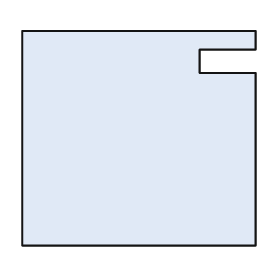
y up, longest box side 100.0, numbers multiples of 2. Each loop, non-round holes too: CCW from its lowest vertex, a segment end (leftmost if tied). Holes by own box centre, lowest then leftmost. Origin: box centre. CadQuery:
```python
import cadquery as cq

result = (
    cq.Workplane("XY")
    .moveTo(-50.0, -46.0)
    .lineTo(50.0, -46.0)
    .lineTo(50.0, 28.0)
    .lineTo(26.0, 28.0)
    .lineTo(26.0, 38.0)
    .lineTo(50.0, 38.0)
    .lineTo(50.0, 46.0)
    .lineTo(-50.0, 46.0)
    .close()
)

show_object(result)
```